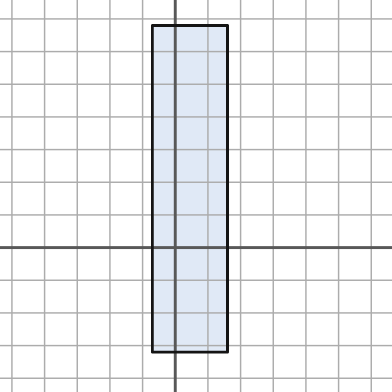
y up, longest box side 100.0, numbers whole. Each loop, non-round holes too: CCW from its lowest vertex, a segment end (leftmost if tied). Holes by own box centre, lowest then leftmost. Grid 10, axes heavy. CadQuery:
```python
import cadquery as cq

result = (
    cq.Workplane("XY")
    .moveTo(-7.0, -32.0)
    .lineTo(16.0, -32.0)
    .lineTo(16.0, 68.0)
    .lineTo(-7.0, 68.0)
    .close()
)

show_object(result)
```